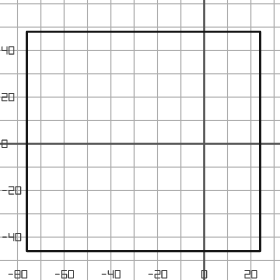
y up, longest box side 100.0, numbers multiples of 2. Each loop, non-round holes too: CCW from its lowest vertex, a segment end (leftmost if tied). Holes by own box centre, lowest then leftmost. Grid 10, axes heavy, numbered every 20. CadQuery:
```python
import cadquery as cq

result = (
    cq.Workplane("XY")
    .moveTo(-76.0, -46.0)
    .lineTo(24.0, -46.0)
    .lineTo(24.0, 48.0)
    .lineTo(-76.0, 48.0)
    .close()
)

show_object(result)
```